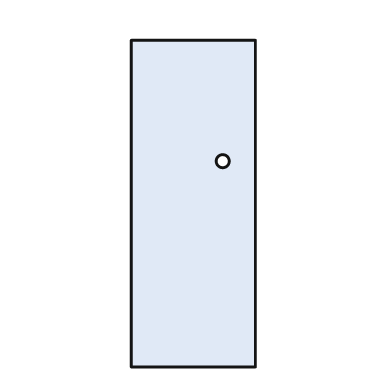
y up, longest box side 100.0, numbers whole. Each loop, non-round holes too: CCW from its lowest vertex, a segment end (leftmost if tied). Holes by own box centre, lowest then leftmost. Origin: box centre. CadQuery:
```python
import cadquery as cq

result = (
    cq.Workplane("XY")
    .moveTo(-19.0, -50.0)
    .lineTo(19.0, -50.0)
    .lineTo(19.0, 50.0)
    .lineTo(-19.0, 50.0)
    .close()
    .moveTo(9.0, 13.0)
    .circle(2.0)
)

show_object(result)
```